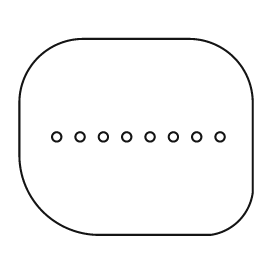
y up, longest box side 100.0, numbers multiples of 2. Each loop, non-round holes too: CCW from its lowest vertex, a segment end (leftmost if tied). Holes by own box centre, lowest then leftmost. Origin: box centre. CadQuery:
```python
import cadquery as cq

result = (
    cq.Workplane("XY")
    .moveTo(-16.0, -42.0)
    .lineTo(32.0, -42.0)
    .threePointArc((44.0, -36.0), (50.0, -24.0))
    .lineTo(50.0, 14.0)
    .threePointArc((42.0, 34.0), (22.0, 42.0))
    .lineTo(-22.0, 42.0)
    .threePointArc((-42.0, 34.0), (-50.0, 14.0))
    .lineTo(-50.0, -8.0)
    .threePointArc((-40.0, -32.0), (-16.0, -42.0))
    .close()
    .moveTo(-34.0, 0.0)
    .circle(2.0)
    .moveTo(-24.0, 0.0)
    .circle(2.0)
    .moveTo(-14.0, 0.0)
    .circle(2.0)
    .moveTo(-4.0, 0.0)
    .circle(2.0)
    .moveTo(6.0, 0.0)
    .circle(2.0)
    .moveTo(16.0, 0.0)
    .circle(2.0)
    .moveTo(26.0, 0.0)
    .circle(2.0)
    .moveTo(36.0, 0.0)
    .circle(2.0)
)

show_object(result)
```